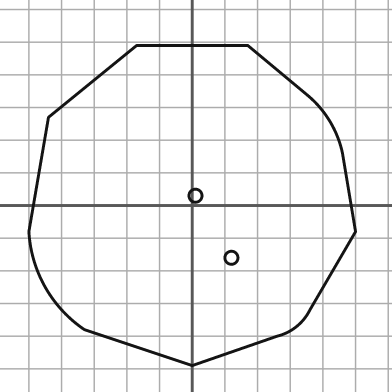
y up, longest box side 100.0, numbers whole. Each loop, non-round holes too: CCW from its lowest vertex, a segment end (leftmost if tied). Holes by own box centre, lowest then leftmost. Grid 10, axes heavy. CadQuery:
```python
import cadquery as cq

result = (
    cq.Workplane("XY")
    .moveTo(0.0, -49.0)
    .lineTo(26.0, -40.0)
    .threePointArc((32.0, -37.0), (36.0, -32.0))
    .lineTo(50.0, -8.0)
    .lineTo(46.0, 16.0)
    .threePointArc((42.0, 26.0), (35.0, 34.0))
    .lineTo(17.0, 49.0)
    .lineTo(-17.0, 49.0)
    .lineTo(-44.0, 27.0)
    .lineTo(-50.0, -8.0)
    .threePointArc((-45.0, -25.0), (-33.0, -38.0))
    .close()
    .moveTo(12.0, -16.0)
    .circle(2.0)
    .moveTo(1.0, 3.0)
    .circle(2.0)
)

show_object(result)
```